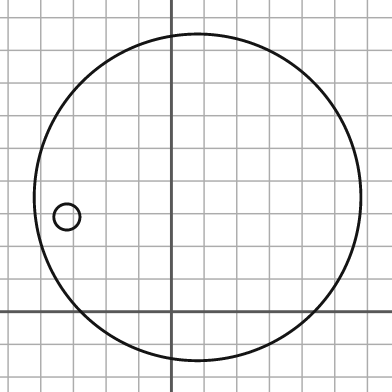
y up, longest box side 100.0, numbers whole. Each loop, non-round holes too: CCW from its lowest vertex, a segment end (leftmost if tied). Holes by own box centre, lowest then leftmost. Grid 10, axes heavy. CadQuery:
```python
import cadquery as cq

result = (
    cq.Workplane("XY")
    .moveTo(8.0, 35.0)
    .circle(50.0)
    .moveTo(-32.0, 29.0)
    .circle(4.0)
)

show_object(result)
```